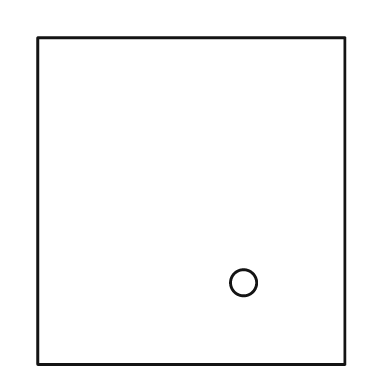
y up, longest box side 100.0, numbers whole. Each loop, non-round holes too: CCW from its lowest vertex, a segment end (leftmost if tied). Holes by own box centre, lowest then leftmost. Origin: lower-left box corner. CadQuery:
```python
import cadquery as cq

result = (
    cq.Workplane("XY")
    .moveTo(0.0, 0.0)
    .lineTo(94.0, 0.0)
    .lineTo(94.0, 100.0)
    .lineTo(0.0, 100.0)
    .close()
    .moveTo(63.0, 25.0)
    .circle(4.0)
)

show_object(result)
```